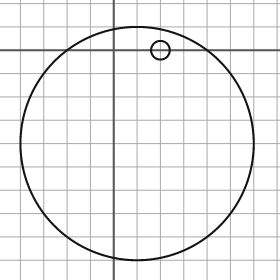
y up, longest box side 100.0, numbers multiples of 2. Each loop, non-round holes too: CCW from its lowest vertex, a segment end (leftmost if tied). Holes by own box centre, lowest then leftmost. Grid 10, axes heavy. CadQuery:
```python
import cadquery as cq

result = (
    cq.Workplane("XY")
    .moveTo(10.0, -40.0)
    .circle(50.0)
    .moveTo(20.0, 0.0)
    .circle(4.0)
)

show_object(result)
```